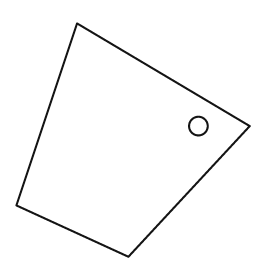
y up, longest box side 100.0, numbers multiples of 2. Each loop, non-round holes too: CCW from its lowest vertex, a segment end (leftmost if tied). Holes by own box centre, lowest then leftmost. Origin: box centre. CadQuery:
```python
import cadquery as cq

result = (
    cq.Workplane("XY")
    .moveTo(-2.0, -50.0)
    .lineTo(50.0, 6.0)
    .lineTo(-24.0, 50.0)
    .lineTo(-50.0, -28.0)
    .close()
    .moveTo(28.0, 6.0)
    .circle(4.0)
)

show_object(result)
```